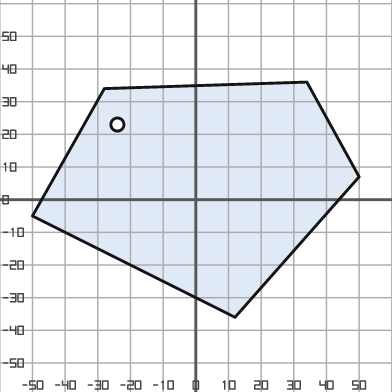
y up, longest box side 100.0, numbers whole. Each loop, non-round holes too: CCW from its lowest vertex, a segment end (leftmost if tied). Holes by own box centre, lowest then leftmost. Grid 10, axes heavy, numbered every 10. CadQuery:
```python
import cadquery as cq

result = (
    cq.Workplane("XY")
    .moveTo(12.0, -36.0)
    .lineTo(50.0, 7.0)
    .lineTo(34.0, 36.0)
    .lineTo(-28.0, 34.0)
    .lineTo(-50.0, -5.0)
    .close()
    .moveTo(-24.0, 23.0)
    .circle(2.0)
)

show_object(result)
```